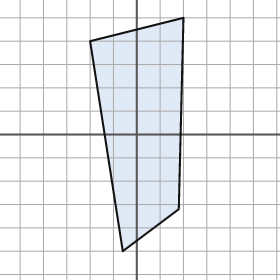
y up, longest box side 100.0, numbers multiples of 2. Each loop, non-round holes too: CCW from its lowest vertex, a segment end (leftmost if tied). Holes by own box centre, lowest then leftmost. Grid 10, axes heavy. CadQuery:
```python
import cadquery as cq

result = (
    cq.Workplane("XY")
    .moveTo(-6.0, -50.0)
    .lineTo(18.0, -32.0)
    .lineTo(20.0, 50.0)
    .lineTo(-20.0, 40.0)
    .close()
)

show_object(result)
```